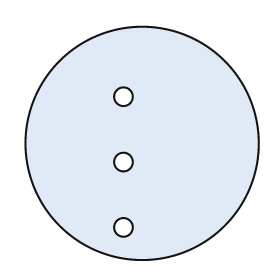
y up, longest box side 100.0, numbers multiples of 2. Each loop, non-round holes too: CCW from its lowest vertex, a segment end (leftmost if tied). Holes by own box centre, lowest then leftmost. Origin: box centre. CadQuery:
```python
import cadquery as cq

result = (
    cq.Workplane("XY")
    .moveTo(0.0, 0.0)
    .circle(50.0)
    .moveTo(-8.0, -36.0)
    .circle(4.0)
    .moveTo(-8.0, -8.0)
    .circle(4.0)
    .moveTo(-8.0, 20.0)
    .circle(4.0)
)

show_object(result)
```